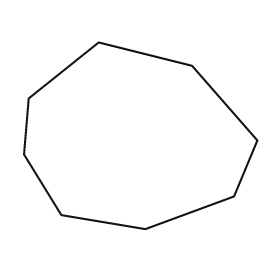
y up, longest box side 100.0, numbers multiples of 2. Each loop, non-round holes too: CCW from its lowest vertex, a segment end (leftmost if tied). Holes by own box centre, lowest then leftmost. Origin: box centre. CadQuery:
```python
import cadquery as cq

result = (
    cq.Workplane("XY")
    .moveTo(2.0, -40.0)
    .lineTo(40.0, -26.0)
    .lineTo(50.0, -2.0)
    .lineTo(22.0, 30.0)
    .lineTo(-18.0, 40.0)
    .lineTo(-48.0, 16.0)
    .lineTo(-50.0, -8.0)
    .lineTo(-34.0, -34.0)
    .close()
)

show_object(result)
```